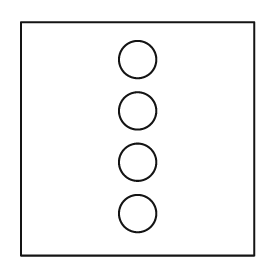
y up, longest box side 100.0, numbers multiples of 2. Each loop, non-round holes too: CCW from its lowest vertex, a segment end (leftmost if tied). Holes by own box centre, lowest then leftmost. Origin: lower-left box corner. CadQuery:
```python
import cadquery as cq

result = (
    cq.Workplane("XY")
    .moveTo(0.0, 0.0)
    .lineTo(100.0, 0.0)
    .lineTo(100.0, 100.0)
    .lineTo(0.0, 100.0)
    .close()
    .moveTo(50.0, 18.0)
    .circle(8.0)
    .moveTo(50.0, 40.0)
    .circle(8.0)
    .moveTo(50.0, 62.0)
    .circle(8.0)
    .moveTo(50.0, 84.0)
    .circle(8.0)
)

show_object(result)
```